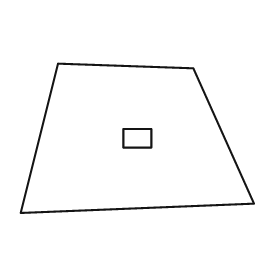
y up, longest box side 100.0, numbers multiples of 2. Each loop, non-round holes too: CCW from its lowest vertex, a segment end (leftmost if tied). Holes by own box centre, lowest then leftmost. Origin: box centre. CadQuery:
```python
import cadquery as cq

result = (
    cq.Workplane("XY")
    .moveTo(-50.0, -32.0)
    .lineTo(50.0, -28.0)
    .lineTo(24.0, 30.0)
    .lineTo(-34.0, 32.0)
    .close()
    .moveTo(-6.0, -4.0)
    .lineTo(6.0, -4.0)
    .lineTo(6.0, 4.0)
    .lineTo(-6.0, 4.0)
    .close()
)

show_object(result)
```